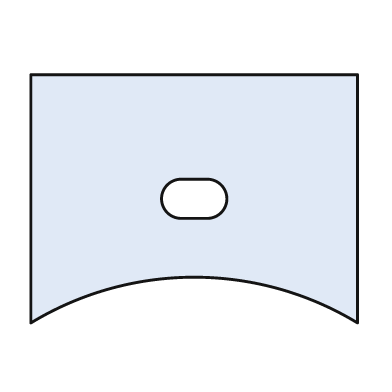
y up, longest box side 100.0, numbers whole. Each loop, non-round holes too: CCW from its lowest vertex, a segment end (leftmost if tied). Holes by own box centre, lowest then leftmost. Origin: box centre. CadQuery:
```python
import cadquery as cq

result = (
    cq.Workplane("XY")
    .moveTo(-50.0, -38.0)
    .threePointArc((0.0, -24.0), (50.0, -38.0))
    .lineTo(50.0, 38.0)
    .lineTo(-50.0, 38.0)
    .close()
    .moveTo(-4.0, -6.0)
    .lineTo(4.0, -6.0)
    .threePointArc((10.0, 0.0), (4.0, 6.0))
    .lineTo(-4.0, 6.0)
    .threePointArc((-10.0, 0.0), (-4.0, -6.0))
    .close()
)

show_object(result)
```